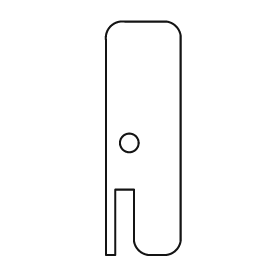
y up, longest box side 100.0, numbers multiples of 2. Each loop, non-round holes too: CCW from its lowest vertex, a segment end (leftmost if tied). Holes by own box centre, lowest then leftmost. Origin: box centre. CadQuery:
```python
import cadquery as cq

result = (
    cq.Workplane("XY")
    .moveTo(-16.0, -50.0)
    .lineTo(-12.0, -50.0)
    .lineTo(-12.0, -22.0)
    .lineTo(-4.0, -22.0)
    .lineTo(-4.0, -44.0)
    .threePointArc((-2.0, -48.0), (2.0, -50.0))
    .lineTo(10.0, -50.0)
    .threePointArc((14.0, -48.0), (16.0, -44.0))
    .lineTo(16.0, 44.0)
    .threePointArc((14.0, 48.0), (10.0, 50.0))
    .lineTo(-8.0, 50.0)
    .threePointArc((-14.0, 48.0), (-16.0, 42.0))
    .close()
    .moveTo(-6.0, -2.0)
    .circle(4.0)
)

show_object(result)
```